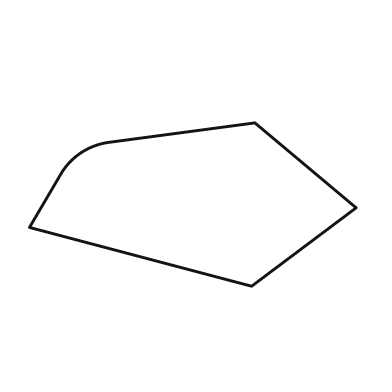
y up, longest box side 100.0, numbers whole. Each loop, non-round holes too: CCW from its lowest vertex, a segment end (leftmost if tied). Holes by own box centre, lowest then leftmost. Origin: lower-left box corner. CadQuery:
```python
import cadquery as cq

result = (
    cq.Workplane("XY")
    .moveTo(68.0, 0.0)
    .lineTo(100.0, 24.0)
    .lineTo(69.0, 50.0)
    .lineTo(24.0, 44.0)
    .threePointArc((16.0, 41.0), (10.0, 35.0))
    .lineTo(0.0, 18.0)
    .close()
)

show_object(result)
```